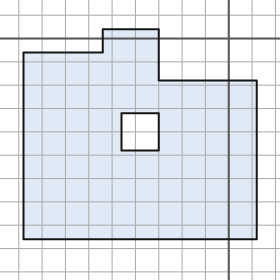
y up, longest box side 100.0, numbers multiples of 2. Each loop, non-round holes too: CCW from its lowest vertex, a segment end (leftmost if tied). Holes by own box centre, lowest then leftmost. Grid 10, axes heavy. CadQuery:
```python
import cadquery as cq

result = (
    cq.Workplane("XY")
    .moveTo(-88.0, -86.0)
    .lineTo(12.0, -86.0)
    .lineTo(12.0, -18.0)
    .lineTo(-30.0, -18.0)
    .lineTo(-30.0, 4.0)
    .lineTo(-54.0, 4.0)
    .lineTo(-54.0, -6.0)
    .lineTo(-88.0, -6.0)
    .close()
    .moveTo(-46.0, -48.0)
    .lineTo(-30.0, -48.0)
    .lineTo(-30.0, -32.0)
    .lineTo(-46.0, -32.0)
    .close()
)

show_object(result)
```